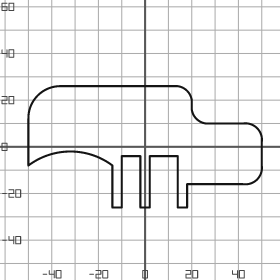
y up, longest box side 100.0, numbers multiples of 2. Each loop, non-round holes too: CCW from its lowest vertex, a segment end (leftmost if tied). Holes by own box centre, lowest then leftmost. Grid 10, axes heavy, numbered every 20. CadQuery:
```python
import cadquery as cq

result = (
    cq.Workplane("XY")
    .moveTo(-14.0, -26.0)
    .lineTo(-10.0, -26.0)
    .lineTo(-10.0, -4.0)
    .lineTo(-2.0, -4.0)
    .lineTo(-2.0, -26.0)
    .lineTo(2.0, -26.0)
    .lineTo(2.0, -4.0)
    .lineTo(14.0, -4.0)
    .lineTo(14.0, -26.0)
    .lineTo(18.0, -26.0)
    .lineTo(18.0, -16.0)
    .lineTo(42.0, -16.0)
    .threePointArc((48.0, -14.0), (50.0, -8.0))
    .lineTo(50.0, 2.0)
    .threePointArc((48.0, 8.0), (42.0, 10.0))
    .lineTo(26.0, 10.0)
    .threePointArc((22.0, 12.0), (20.0, 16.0))
    .lineTo(20.0, 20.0)
    .threePointArc((18.0, 24.0), (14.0, 26.0))
    .lineTo(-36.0, 26.0)
    .threePointArc((-46.0, 22.0), (-50.0, 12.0))
    .lineTo(-50.0, -8.0)
    .threePointArc((-32.0, -2.0), (-14.0, -8.0))
    .close()
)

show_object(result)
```